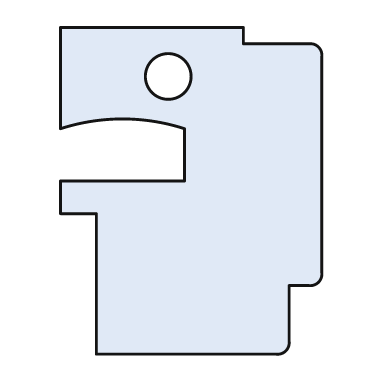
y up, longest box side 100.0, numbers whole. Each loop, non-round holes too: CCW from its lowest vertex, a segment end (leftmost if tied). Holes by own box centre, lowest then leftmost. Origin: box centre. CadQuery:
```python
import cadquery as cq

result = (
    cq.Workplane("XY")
    .moveTo(-29.0, -50.0)
    .lineTo(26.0, -50.0)
    .threePointArc((29.0, -49.0), (30.0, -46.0))
    .lineTo(30.0, -29.0)
    .lineTo(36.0, -29.0)
    .threePointArc((39.0, -28.0), (40.0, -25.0))
    .lineTo(40.0, 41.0)
    .threePointArc((39.0, 44.0), (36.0, 45.0))
    .lineTo(16.0, 45.0)
    .lineTo(16.0, 50.0)
    .lineTo(-40.0, 50.0)
    .lineTo(-40.0, 19.0)
    .threePointArc((-21.0, 22.0), (-2.0, 19.0))
    .lineTo(-2.0, 3.0)
    .lineTo(-40.0, 3.0)
    .lineTo(-40.0, -7.0)
    .lineTo(-29.0, -7.0)
    .close()
    .moveTo(-7.0, 35.0)
    .circle(7.0)
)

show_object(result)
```